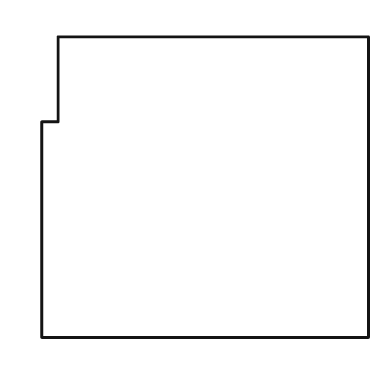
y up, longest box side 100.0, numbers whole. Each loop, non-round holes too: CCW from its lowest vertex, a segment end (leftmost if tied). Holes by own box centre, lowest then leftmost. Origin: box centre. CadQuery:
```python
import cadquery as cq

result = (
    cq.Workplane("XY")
    .moveTo(-50.0, -46.0)
    .lineTo(50.0, -46.0)
    .lineTo(50.0, 46.0)
    .lineTo(-45.0, 46.0)
    .lineTo(-45.0, 20.0)
    .lineTo(-50.0, 20.0)
    .close()
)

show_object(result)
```